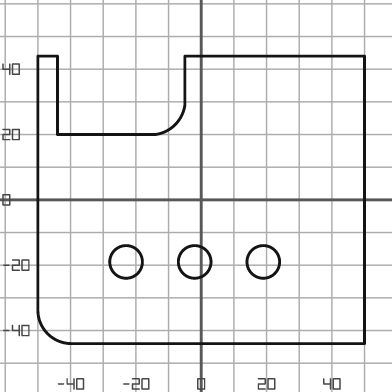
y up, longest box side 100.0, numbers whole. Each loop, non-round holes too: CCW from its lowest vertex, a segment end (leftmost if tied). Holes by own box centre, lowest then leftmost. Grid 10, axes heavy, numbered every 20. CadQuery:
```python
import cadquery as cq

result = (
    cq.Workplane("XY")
    .moveTo(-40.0, -44.0)
    .lineTo(50.0, -44.0)
    .lineTo(50.0, 44.0)
    .lineTo(-5.0, 44.0)
    .lineTo(-5.0, 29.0)
    .threePointArc((-8.0, 23.0), (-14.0, 20.0))
    .lineTo(-44.0, 20.0)
    .lineTo(-44.0, 44.0)
    .lineTo(-50.0, 44.0)
    .lineTo(-50.0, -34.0)
    .threePointArc((-47.0, -41.0), (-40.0, -44.0))
    .close()
    .moveTo(-23.0, -19.0)
    .circle(5.0)
    .moveTo(-2.0, -19.0)
    .circle(5.0)
    .moveTo(19.0, -19.0)
    .circle(5.0)
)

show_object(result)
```